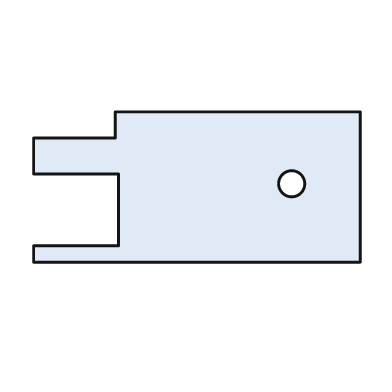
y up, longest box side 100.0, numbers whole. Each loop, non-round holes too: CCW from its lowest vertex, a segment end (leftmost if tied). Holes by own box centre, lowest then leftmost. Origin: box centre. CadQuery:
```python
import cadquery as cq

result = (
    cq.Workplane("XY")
    .moveTo(-50.0, -23.0)
    .lineTo(50.0, -23.0)
    .lineTo(50.0, 23.0)
    .lineTo(-25.0, 23.0)
    .lineTo(-25.0, 15.0)
    .lineTo(-50.0, 15.0)
    .lineTo(-50.0, 4.0)
    .lineTo(-24.0, 4.0)
    .lineTo(-24.0, -18.0)
    .lineTo(-50.0, -18.0)
    .close()
    .moveTo(29.0, 1.0)
    .circle(4.0)
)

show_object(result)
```